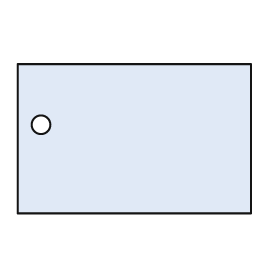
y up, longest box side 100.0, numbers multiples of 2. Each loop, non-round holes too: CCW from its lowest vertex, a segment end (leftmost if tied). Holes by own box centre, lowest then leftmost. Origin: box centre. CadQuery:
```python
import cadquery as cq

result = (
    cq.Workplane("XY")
    .moveTo(-50.0, -32.0)
    .lineTo(50.0, -32.0)
    .lineTo(50.0, 32.0)
    .lineTo(-50.0, 32.0)
    .close()
    .moveTo(-40.0, 6.0)
    .circle(4.0)
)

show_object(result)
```